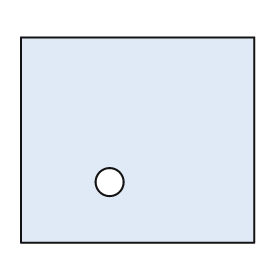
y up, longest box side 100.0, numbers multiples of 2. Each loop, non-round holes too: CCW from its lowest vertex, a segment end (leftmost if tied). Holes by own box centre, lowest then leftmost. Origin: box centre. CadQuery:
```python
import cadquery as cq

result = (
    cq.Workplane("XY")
    .moveTo(-50.0, -44.0)
    .lineTo(50.0, -44.0)
    .lineTo(50.0, 44.0)
    .lineTo(-50.0, 44.0)
    .close()
    .moveTo(-12.0, -18.0)
    .circle(6.0)
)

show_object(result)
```